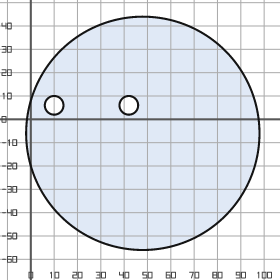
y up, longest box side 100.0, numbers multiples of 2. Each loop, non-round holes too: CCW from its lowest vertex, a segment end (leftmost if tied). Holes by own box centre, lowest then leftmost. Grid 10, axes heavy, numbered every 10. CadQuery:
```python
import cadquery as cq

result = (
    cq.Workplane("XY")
    .moveTo(48.0, -6.0)
    .circle(50.0)
    .moveTo(10.0, 6.0)
    .circle(4.0)
    .moveTo(42.0, 6.0)
    .circle(4.0)
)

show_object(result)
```